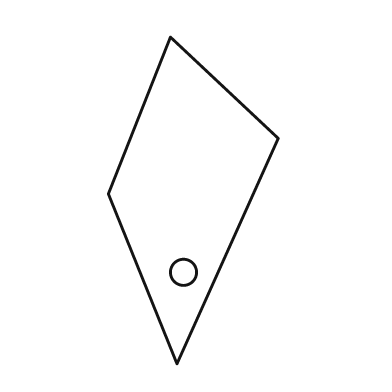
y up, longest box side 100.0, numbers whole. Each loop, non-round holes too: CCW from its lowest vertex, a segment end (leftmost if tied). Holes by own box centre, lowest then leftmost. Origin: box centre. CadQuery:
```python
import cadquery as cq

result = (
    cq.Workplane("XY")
    .moveTo(-5.0, -50.0)
    .lineTo(26.0, 19.0)
    .lineTo(-7.0, 50.0)
    .lineTo(-26.0, 2.0)
    .close()
    .moveTo(-3.0, -22.0)
    .circle(4.0)
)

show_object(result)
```